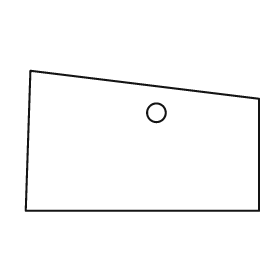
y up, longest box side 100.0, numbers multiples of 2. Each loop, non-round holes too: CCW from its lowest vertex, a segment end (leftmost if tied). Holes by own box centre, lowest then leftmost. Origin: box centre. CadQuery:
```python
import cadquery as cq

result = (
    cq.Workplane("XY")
    .moveTo(-50.0, -30.0)
    .lineTo(50.0, -30.0)
    .lineTo(50.0, 18.0)
    .lineTo(-48.0, 30.0)
    .close()
    .moveTo(6.0, 12.0)
    .circle(4.0)
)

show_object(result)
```